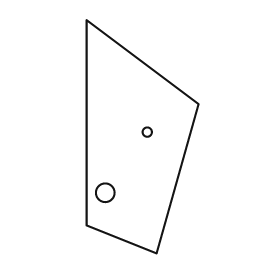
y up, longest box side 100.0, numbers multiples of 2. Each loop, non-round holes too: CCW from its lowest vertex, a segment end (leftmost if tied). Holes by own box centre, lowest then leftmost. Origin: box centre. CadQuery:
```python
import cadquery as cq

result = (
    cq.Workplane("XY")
    .moveTo(6.0, -50.0)
    .lineTo(24.0, 14.0)
    .lineTo(-24.0, 50.0)
    .lineTo(-24.0, -38.0)
    .close()
    .moveTo(-16.0, -24.0)
    .circle(4.0)
    .moveTo(2.0, 2.0)
    .circle(2.0)
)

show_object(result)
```